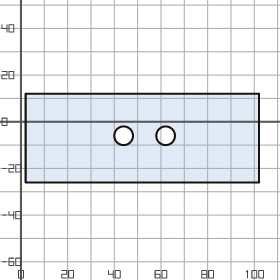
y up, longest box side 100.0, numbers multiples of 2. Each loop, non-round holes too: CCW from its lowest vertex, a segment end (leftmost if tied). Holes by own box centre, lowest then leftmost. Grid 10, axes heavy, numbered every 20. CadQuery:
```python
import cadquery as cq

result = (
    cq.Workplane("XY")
    .moveTo(2.0, -26.0)
    .lineTo(102.0, -26.0)
    .lineTo(102.0, 12.0)
    .lineTo(2.0, 12.0)
    .close()
    .moveTo(44.0, -6.0)
    .circle(4.0)
    .moveTo(62.0, -6.0)
    .circle(4.0)
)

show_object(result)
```